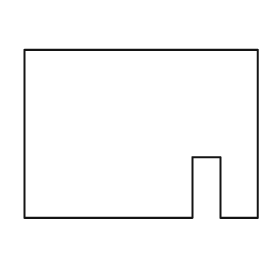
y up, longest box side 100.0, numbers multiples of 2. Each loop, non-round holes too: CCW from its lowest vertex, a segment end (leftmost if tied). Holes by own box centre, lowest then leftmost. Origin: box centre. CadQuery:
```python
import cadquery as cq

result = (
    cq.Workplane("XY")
    .moveTo(-50.0, -36.0)
    .lineTo(22.0, -36.0)
    .lineTo(22.0, -10.0)
    .lineTo(34.0, -10.0)
    .lineTo(34.0, -36.0)
    .lineTo(50.0, -36.0)
    .lineTo(50.0, 36.0)
    .lineTo(-50.0, 36.0)
    .close()
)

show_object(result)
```